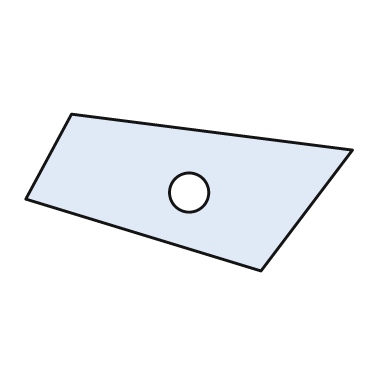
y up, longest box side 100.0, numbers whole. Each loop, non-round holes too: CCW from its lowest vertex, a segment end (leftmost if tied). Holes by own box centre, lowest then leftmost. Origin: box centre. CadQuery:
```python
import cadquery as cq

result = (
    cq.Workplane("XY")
    .moveTo(22.0, -24.0)
    .lineTo(50.0, 13.0)
    .lineTo(-36.0, 24.0)
    .lineTo(-50.0, -2.0)
    .close()
    .moveTo(0.0, 0.0)
    .circle(6.0)
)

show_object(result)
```